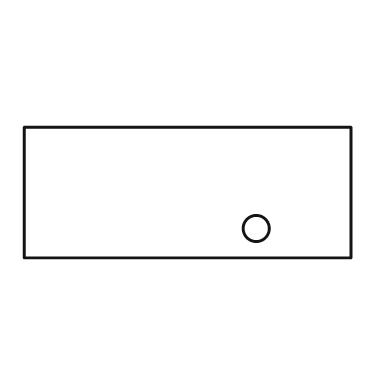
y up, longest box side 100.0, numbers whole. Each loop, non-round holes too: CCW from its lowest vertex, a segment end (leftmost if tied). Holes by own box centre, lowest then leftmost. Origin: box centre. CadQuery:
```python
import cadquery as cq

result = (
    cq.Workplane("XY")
    .moveTo(-50.0, -20.0)
    .lineTo(50.0, -20.0)
    .lineTo(50.0, 20.0)
    .lineTo(-50.0, 20.0)
    .close()
    .moveTo(21.0, -11.0)
    .circle(4.0)
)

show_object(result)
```